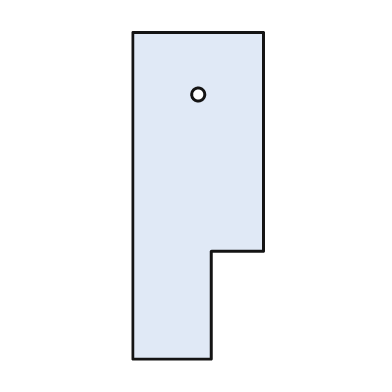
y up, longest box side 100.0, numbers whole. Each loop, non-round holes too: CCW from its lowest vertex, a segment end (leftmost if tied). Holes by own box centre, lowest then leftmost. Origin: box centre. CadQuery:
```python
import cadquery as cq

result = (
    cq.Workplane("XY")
    .moveTo(-20.0, -50.0)
    .lineTo(4.0, -50.0)
    .lineTo(4.0, -17.0)
    .lineTo(20.0, -17.0)
    .lineTo(20.0, 50.0)
    .lineTo(-20.0, 50.0)
    .close()
    .moveTo(0.0, 31.0)
    .circle(2.0)
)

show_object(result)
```